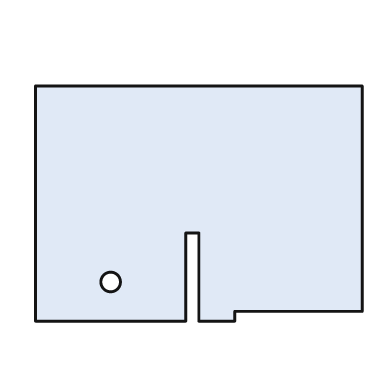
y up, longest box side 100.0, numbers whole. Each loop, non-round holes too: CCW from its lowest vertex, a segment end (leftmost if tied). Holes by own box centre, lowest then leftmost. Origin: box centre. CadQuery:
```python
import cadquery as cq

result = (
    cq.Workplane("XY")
    .moveTo(-50.0, -36.0)
    .lineTo(-4.0, -36.0)
    .lineTo(-4.0, -9.0)
    .lineTo(0.0, -9.0)
    .lineTo(0.0, -36.0)
    .lineTo(11.0, -36.0)
    .lineTo(11.0, -33.0)
    .lineTo(50.0, -33.0)
    .lineTo(50.0, 36.0)
    .lineTo(-50.0, 36.0)
    .close()
    .moveTo(-27.0, -24.0)
    .circle(3.0)
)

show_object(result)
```